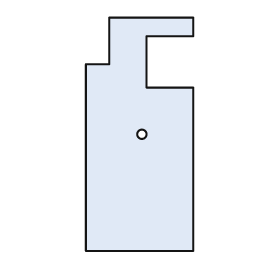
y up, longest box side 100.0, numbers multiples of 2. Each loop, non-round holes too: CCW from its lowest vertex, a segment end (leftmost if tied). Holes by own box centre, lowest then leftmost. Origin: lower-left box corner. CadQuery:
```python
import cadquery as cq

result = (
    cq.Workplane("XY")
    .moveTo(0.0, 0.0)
    .lineTo(46.0, 0.0)
    .lineTo(46.0, 70.0)
    .lineTo(26.0, 70.0)
    .lineTo(26.0, 92.0)
    .lineTo(46.0, 92.0)
    .lineTo(46.0, 100.0)
    .lineTo(10.0, 100.0)
    .lineTo(10.0, 80.0)
    .lineTo(0.0, 80.0)
    .close()
    .moveTo(24.0, 50.0)
    .circle(2.0)
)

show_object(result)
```